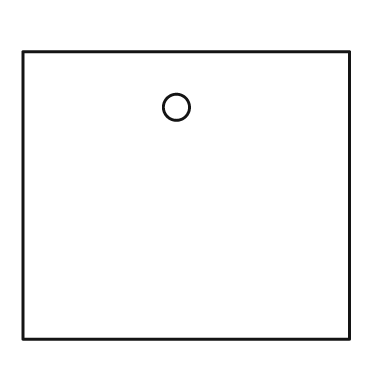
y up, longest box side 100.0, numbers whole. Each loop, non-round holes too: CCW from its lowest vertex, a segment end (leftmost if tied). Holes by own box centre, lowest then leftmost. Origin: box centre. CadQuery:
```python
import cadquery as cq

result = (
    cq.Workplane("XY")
    .moveTo(-50.0, -44.0)
    .lineTo(50.0, -44.0)
    .lineTo(50.0, 44.0)
    .lineTo(-50.0, 44.0)
    .close()
    .moveTo(-3.0, 27.0)
    .circle(4.0)
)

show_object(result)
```